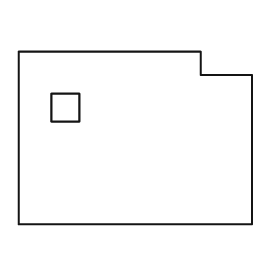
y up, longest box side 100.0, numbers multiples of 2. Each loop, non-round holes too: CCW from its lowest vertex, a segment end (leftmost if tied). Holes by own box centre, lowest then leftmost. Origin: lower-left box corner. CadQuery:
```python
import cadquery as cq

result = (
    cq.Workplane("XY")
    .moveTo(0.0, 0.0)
    .lineTo(100.0, 0.0)
    .lineTo(100.0, 64.0)
    .lineTo(78.0, 64.0)
    .lineTo(78.0, 74.0)
    .lineTo(0.0, 74.0)
    .close()
    .moveTo(14.0, 44.0)
    .lineTo(26.0, 44.0)
    .lineTo(26.0, 56.0)
    .lineTo(14.0, 56.0)
    .close()
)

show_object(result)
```